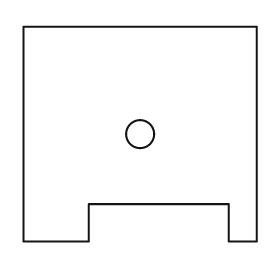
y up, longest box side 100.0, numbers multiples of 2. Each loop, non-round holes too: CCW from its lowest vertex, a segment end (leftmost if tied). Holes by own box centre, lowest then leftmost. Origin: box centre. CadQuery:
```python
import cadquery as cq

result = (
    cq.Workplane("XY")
    .moveTo(-50.0, -46.0)
    .lineTo(-22.0, -46.0)
    .lineTo(-22.0, -30.0)
    .lineTo(38.0, -30.0)
    .lineTo(38.0, -46.0)
    .lineTo(50.0, -46.0)
    .lineTo(50.0, 46.0)
    .lineTo(-50.0, 46.0)
    .close()
    .moveTo(0.0, 0.0)
    .circle(6.0)
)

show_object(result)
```